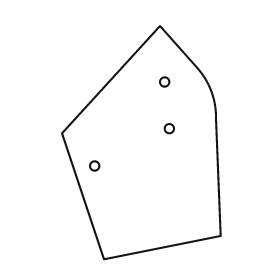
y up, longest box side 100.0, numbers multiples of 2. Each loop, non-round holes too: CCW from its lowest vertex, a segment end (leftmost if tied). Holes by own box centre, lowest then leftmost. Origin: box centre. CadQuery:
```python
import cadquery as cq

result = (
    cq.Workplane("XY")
    .moveTo(-16.0, -50.0)
    .lineTo(34.0, -40.0)
    .lineTo(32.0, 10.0)
    .threePointArc((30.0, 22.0), (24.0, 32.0))
    .lineTo(8.0, 50.0)
    .lineTo(-34.0, 4.0)
    .close()
    .moveTo(-20.0, -10.0)
    .circle(2.0)
    .moveTo(12.0, 6.0)
    .circle(2.0)
    .moveTo(10.0, 26.0)
    .circle(2.0)
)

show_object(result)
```